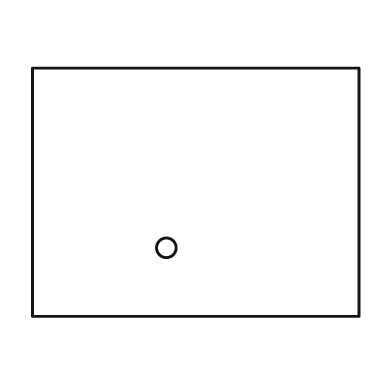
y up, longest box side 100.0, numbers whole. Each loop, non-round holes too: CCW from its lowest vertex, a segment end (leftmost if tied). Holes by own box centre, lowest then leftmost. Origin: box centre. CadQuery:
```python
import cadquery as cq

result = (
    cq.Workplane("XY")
    .moveTo(-50.0, -38.0)
    .lineTo(50.0, -38.0)
    .lineTo(50.0, 38.0)
    .lineTo(-50.0, 38.0)
    .close()
    .moveTo(-9.0, -17.0)
    .circle(3.0)
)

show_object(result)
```